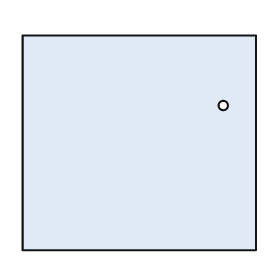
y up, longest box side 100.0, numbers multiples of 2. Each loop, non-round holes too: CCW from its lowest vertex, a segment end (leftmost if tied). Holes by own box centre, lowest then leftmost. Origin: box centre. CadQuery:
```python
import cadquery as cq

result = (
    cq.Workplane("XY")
    .moveTo(-50.0, -46.0)
    .lineTo(50.0, -46.0)
    .lineTo(50.0, 46.0)
    .lineTo(-50.0, 46.0)
    .close()
    .moveTo(36.0, 16.0)
    .circle(2.0)
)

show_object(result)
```